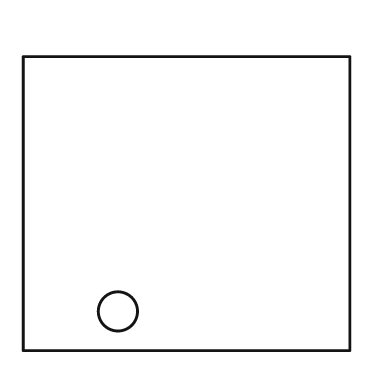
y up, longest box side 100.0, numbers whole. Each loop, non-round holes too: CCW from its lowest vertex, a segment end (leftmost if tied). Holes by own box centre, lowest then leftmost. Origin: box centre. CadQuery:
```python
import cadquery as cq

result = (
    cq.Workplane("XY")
    .moveTo(-50.0, -45.0)
    .lineTo(50.0, -45.0)
    .lineTo(50.0, 45.0)
    .lineTo(-50.0, 45.0)
    .close()
    .moveTo(-21.0, -33.0)
    .circle(6.0)
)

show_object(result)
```